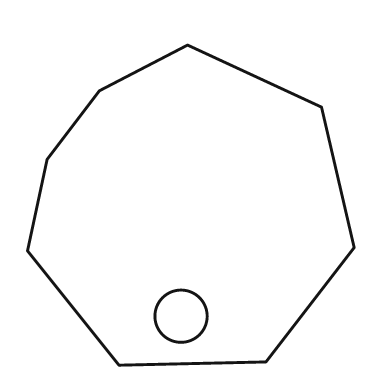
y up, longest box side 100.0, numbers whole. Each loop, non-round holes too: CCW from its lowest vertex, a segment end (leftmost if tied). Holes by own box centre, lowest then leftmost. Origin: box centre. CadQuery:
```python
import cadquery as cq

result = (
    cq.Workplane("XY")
    .moveTo(-22.0, -49.0)
    .lineTo(23.0, -48.0)
    .lineTo(50.0, -13.0)
    .lineTo(40.0, 30.0)
    .lineTo(-1.0, 49.0)
    .lineTo(-28.0, 35.0)
    .lineTo(-44.0, 14.0)
    .lineTo(-50.0, -14.0)
    .close()
    .moveTo(-3.0, -34.0)
    .circle(8.0)
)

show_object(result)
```